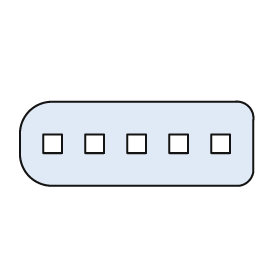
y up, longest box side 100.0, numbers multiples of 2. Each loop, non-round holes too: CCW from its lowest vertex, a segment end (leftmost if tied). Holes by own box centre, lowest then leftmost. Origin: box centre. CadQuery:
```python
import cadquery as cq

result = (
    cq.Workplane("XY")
    .moveTo(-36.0, -18.0)
    .lineTo(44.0, -18.0)
    .threePointArc((48.0, -16.0), (50.0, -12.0))
    .lineTo(50.0, 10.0)
    .threePointArc((48.0, 16.0), (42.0, 18.0))
    .lineTo(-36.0, 18.0)
    .threePointArc((-46.0, 14.0), (-50.0, 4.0))
    .lineTo(-50.0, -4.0)
    .threePointArc((-46.0, -14.0), (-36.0, -18.0))
    .close()
    .moveTo(-40.0, -4.0)
    .lineTo(-32.0, -4.0)
    .lineTo(-32.0, 4.0)
    .lineTo(-40.0, 4.0)
    .close()
    .moveTo(-22.0, -4.0)
    .lineTo(-14.0, -4.0)
    .lineTo(-14.0, 4.0)
    .lineTo(-22.0, 4.0)
    .close()
    .moveTo(-4.0, -4.0)
    .lineTo(4.0, -4.0)
    .lineTo(4.0, 4.0)
    .lineTo(-4.0, 4.0)
    .close()
    .moveTo(14.0, -4.0)
    .lineTo(22.0, -4.0)
    .lineTo(22.0, 4.0)
    .lineTo(14.0, 4.0)
    .close()
    .moveTo(32.0, -4.0)
    .lineTo(40.0, -4.0)
    .lineTo(40.0, 4.0)
    .lineTo(32.0, 4.0)
    .close()
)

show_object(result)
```